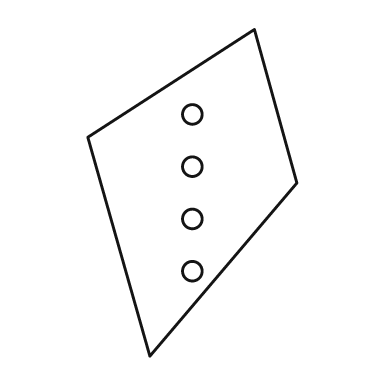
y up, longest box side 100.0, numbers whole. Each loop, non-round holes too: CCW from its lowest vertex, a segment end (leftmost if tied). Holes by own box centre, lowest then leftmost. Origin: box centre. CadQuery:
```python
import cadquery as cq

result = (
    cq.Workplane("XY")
    .moveTo(-13.0, -50.0)
    .lineTo(32.0, 3.0)
    .lineTo(19.0, 50.0)
    .lineTo(-32.0, 17.0)
    .close()
    .moveTo(0.0, -24.0)
    .circle(3.0)
    .moveTo(0.0, -8.0)
    .circle(3.0)
    .moveTo(0.0, 8.0)
    .circle(3.0)
    .moveTo(0.0, 24.0)
    .circle(3.0)
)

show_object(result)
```